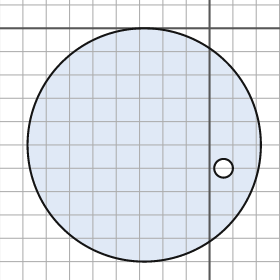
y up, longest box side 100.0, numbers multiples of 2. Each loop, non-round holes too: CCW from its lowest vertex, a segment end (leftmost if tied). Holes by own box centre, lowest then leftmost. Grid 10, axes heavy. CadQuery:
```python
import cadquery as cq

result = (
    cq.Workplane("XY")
    .moveTo(-28.0, -50.0)
    .circle(50.0)
    .moveTo(6.0, -60.0)
    .circle(4.0)
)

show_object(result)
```